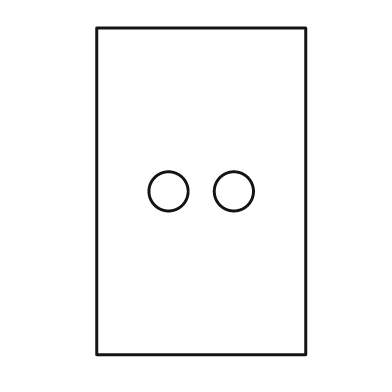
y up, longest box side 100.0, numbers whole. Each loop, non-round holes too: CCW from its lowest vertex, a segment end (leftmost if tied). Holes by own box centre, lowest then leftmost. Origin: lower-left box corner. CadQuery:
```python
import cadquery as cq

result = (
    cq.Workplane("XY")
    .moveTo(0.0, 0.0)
    .lineTo(64.0, 0.0)
    .lineTo(64.0, 100.0)
    .lineTo(0.0, 100.0)
    .close()
    .moveTo(22.0, 50.0)
    .circle(6.0)
    .moveTo(42.0, 50.0)
    .circle(6.0)
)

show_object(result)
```